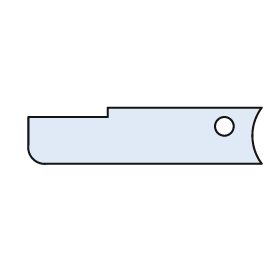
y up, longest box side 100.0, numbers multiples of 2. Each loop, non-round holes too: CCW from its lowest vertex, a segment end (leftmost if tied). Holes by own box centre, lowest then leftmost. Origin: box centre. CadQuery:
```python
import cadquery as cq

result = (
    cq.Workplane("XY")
    .moveTo(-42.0, -12.0)
    .lineTo(50.0, -12.0)
    .threePointArc((46.0, 0.0), (50.0, 12.0))
    .lineTo(-16.0, 12.0)
    .lineTo(-16.0, 8.0)
    .lineTo(-50.0, 8.0)
    .lineTo(-50.0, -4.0)
    .threePointArc((-48.0, -10.0), (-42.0, -12.0))
    .close()
    .moveTo(34.0, 4.0)
    .circle(4.0)
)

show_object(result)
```